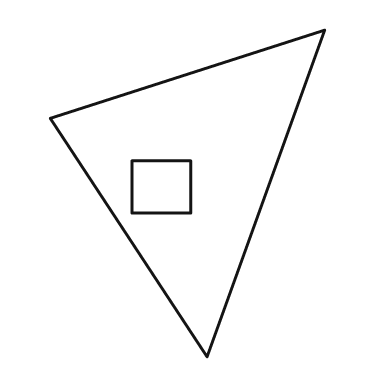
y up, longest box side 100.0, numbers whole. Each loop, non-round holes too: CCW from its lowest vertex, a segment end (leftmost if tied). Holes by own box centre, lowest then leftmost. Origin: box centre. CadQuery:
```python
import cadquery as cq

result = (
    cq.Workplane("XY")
    .moveTo(6.0, -50.0)
    .lineTo(42.0, 50.0)
    .lineTo(-42.0, 23.0)
    .close()
    .moveTo(-17.0, -6.0)
    .lineTo(1.0, -6.0)
    .lineTo(1.0, 10.0)
    .lineTo(-17.0, 10.0)
    .close()
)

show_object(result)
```